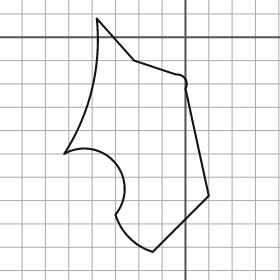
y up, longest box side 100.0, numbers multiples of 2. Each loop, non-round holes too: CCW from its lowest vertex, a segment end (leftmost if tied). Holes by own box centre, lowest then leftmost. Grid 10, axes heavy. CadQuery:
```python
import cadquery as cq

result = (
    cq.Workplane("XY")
    .moveTo(-14.0, -92.0)
    .lineTo(10.0, -68.0)
    .lineTo(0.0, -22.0)
    .threePointArc((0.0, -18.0), (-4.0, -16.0))
    .lineTo(-22.0, -10.0)
    .lineTo(-38.0, 8.0)
    .threePointArc((-40.0, -22.0), (-52.0, -50.0))
    .threePointArc((-30.0, -54.0), (-30.0, -76.0))
    .threePointArc((-24.0, -86.0), (-14.0, -92.0))
    .close()
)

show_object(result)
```